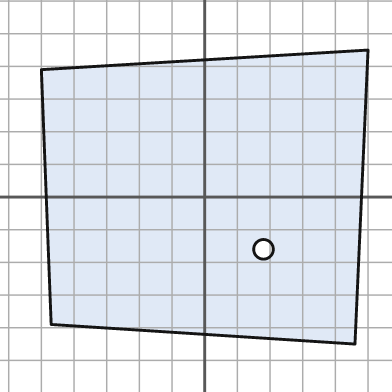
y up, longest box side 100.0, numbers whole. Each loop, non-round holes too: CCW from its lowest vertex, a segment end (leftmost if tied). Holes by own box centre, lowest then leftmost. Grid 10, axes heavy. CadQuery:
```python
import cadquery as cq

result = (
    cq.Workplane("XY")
    .moveTo(46.0, -45.0)
    .lineTo(50.0, 45.0)
    .lineTo(-50.0, 39.0)
    .lineTo(-47.0, -39.0)
    .close()
    .moveTo(18.0, -16.0)
    .circle(3.0)
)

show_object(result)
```